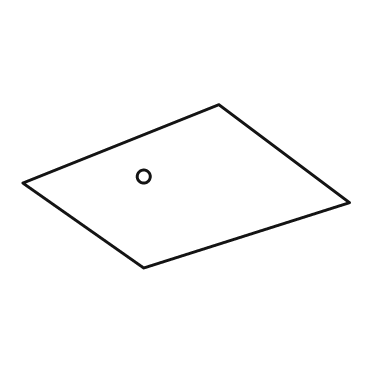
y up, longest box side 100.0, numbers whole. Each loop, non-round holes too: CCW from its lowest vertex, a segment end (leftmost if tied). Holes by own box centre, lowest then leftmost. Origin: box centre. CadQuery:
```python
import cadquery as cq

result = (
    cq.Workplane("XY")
    .moveTo(-13.0, -25.0)
    .lineTo(50.0, -5.0)
    .lineTo(10.0, 25.0)
    .lineTo(-50.0, 1.0)
    .close()
    .moveTo(-13.0, 3.0)
    .circle(2.0)
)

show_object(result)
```